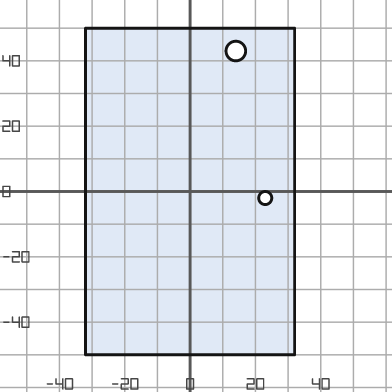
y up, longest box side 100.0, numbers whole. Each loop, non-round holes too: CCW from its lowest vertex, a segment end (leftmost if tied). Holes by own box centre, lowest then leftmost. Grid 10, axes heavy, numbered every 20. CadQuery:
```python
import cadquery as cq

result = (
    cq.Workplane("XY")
    .moveTo(-32.0, -50.0)
    .lineTo(32.0, -50.0)
    .lineTo(32.0, 50.0)
    .lineTo(-32.0, 50.0)
    .close()
    .moveTo(23.0, -2.0)
    .circle(2.0)
    .moveTo(14.0, 43.0)
    .circle(3.0)
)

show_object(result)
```